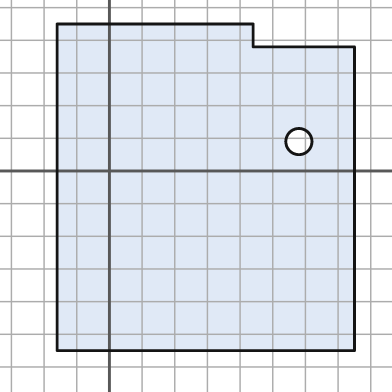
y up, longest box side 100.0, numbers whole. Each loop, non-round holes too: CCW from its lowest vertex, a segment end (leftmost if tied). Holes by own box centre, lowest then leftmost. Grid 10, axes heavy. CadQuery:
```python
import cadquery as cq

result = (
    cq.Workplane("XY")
    .moveTo(-16.0, -55.0)
    .lineTo(75.0, -55.0)
    .lineTo(75.0, 38.0)
    .lineTo(44.0, 38.0)
    .lineTo(44.0, 45.0)
    .lineTo(-16.0, 45.0)
    .close()
    .moveTo(58.0, 9.0)
    .circle(4.0)
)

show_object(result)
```